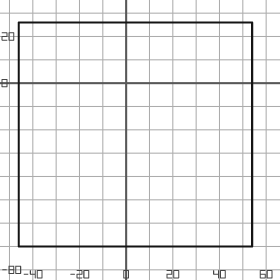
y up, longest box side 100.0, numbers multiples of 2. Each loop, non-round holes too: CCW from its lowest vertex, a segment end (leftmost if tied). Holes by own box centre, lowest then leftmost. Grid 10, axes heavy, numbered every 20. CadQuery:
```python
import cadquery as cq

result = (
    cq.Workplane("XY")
    .moveTo(-46.0, -70.0)
    .lineTo(54.0, -70.0)
    .lineTo(54.0, 26.0)
    .lineTo(-46.0, 26.0)
    .close()
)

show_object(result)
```